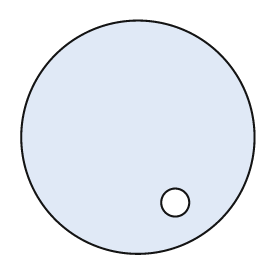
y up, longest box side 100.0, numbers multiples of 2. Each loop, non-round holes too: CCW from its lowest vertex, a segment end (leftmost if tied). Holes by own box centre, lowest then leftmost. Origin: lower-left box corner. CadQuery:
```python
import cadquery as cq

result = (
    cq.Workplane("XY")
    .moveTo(50.0, 50.0)
    .circle(50.0)
    .moveTo(66.0, 22.0)
    .circle(6.0)
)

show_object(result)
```